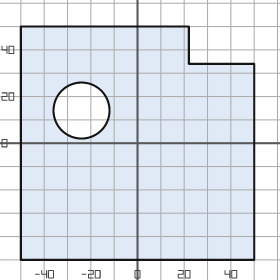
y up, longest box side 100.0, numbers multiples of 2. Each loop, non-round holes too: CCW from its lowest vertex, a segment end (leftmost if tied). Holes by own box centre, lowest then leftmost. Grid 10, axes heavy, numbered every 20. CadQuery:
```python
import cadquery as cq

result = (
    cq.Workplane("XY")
    .moveTo(-50.0, -50.0)
    .lineTo(50.0, -50.0)
    .lineTo(50.0, 34.0)
    .lineTo(22.0, 34.0)
    .lineTo(22.0, 50.0)
    .lineTo(-50.0, 50.0)
    .close()
    .moveTo(-24.0, 14.0)
    .circle(12.0)
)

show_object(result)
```